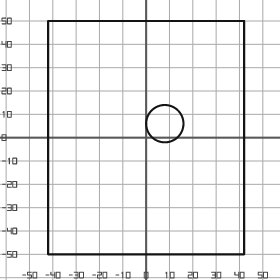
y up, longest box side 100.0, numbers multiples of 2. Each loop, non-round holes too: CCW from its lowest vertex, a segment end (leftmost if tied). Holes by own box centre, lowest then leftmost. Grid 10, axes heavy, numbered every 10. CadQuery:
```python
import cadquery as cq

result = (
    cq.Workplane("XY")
    .moveTo(-42.0, -50.0)
    .lineTo(42.0, -50.0)
    .lineTo(42.0, 50.0)
    .lineTo(-42.0, 50.0)
    .close()
    .moveTo(8.0, 6.0)
    .circle(8.0)
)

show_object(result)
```